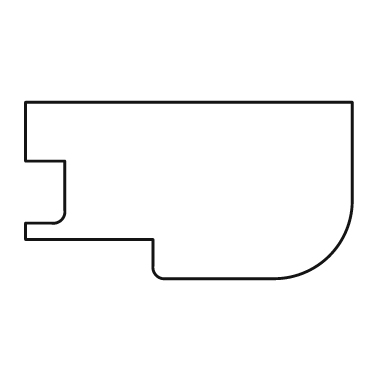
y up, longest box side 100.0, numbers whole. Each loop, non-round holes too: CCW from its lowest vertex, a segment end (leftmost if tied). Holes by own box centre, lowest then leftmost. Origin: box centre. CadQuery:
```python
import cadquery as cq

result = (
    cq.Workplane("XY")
    .moveTo(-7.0, -27.0)
    .lineTo(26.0, -27.0)
    .threePointArc((43.0, -20.0), (50.0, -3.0))
    .lineTo(50.0, 27.0)
    .lineTo(-50.0, 27.0)
    .lineTo(-50.0, 9.0)
    .lineTo(-38.0, 9.0)
    .lineTo(-38.0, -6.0)
    .threePointArc((-39.0, -9.0), (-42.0, -10.0))
    .lineTo(-50.0, -10.0)
    .lineTo(-50.0, -15.0)
    .lineTo(-11.0, -15.0)
    .lineTo(-11.0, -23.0)
    .threePointArc((-10.0, -26.0), (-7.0, -27.0))
    .close()
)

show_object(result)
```